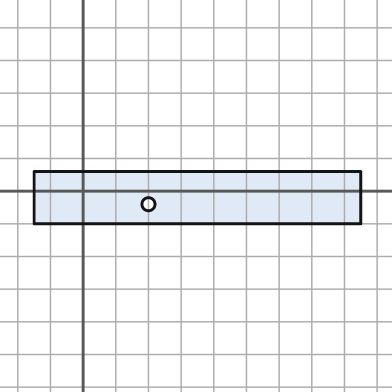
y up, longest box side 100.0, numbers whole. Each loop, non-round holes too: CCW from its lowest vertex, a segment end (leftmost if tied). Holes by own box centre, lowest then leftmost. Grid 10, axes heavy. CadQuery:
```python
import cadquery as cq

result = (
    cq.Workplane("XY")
    .moveTo(-15.0, -10.0)
    .lineTo(85.0, -10.0)
    .lineTo(85.0, 6.0)
    .lineTo(-15.0, 6.0)
    .close()
    .moveTo(20.0, -4.0)
    .circle(2.0)
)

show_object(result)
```